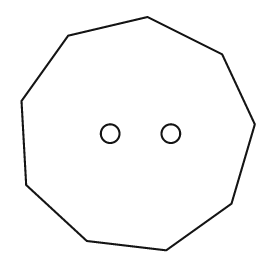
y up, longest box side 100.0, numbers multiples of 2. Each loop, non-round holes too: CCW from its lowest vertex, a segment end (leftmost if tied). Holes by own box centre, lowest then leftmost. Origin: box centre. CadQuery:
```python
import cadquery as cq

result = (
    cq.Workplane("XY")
    .moveTo(12.0, -50.0)
    .lineTo(40.0, -30.0)
    .lineTo(50.0, 4.0)
    .lineTo(36.0, 34.0)
    .lineTo(4.0, 50.0)
    .lineTo(-30.0, 42.0)
    .lineTo(-50.0, 14.0)
    .lineTo(-48.0, -22.0)
    .lineTo(-22.0, -46.0)
    .close()
    .moveTo(-12.0, 0.0)
    .circle(4.0)
    .moveTo(14.0, 0.0)
    .circle(4.0)
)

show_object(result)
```